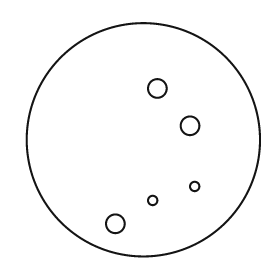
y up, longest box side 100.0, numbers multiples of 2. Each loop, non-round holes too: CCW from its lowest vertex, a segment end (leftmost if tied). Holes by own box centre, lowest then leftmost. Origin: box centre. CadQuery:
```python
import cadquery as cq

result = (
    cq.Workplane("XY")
    .moveTo(0.0, 0.0)
    .circle(50.0)
    .moveTo(-12.0, -36.0)
    .circle(4.0)
    .moveTo(4.0, -26.0)
    .circle(2.0)
    .moveTo(22.0, -20.0)
    .circle(2.0)
    .moveTo(20.0, 6.0)
    .circle(4.0)
    .moveTo(6.0, 22.0)
    .circle(4.0)
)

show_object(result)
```